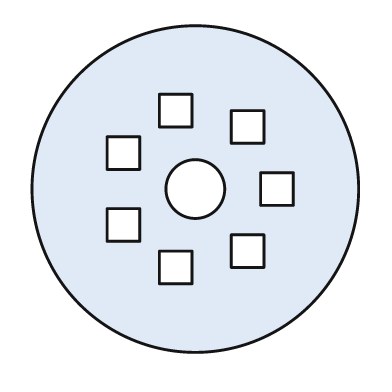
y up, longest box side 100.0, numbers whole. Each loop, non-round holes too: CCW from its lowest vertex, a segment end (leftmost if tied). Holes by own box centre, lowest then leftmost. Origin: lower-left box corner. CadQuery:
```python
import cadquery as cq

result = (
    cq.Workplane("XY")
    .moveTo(50.0, 50.0)
    .circle(50.0)
    .moveTo(39.0, 21.0)
    .lineTo(49.0, 21.0)
    .lineTo(49.0, 31.0)
    .lineTo(39.0, 31.0)
    .close()
    .moveTo(61.0, 26.0)
    .lineTo(71.0, 26.0)
    .lineTo(71.0, 36.0)
    .lineTo(61.0, 36.0)
    .close()
    .moveTo(23.0, 34.0)
    .lineTo(33.0, 34.0)
    .lineTo(33.0, 44.0)
    .lineTo(23.0, 44.0)
    .close()
    .moveTo(50.0, 50.0)
    .circle(9.0)
    .moveTo(70.0, 45.0)
    .lineTo(80.0, 45.0)
    .lineTo(80.0, 55.0)
    .lineTo(70.0, 55.0)
    .close()
    .moveTo(23.0, 56.0)
    .lineTo(33.0, 56.0)
    .lineTo(33.0, 66.0)
    .lineTo(23.0, 66.0)
    .close()
    .moveTo(61.0, 64.0)
    .lineTo(71.0, 64.0)
    .lineTo(71.0, 74.0)
    .lineTo(61.0, 74.0)
    .close()
    .moveTo(39.0, 69.0)
    .lineTo(49.0, 69.0)
    .lineTo(49.0, 79.0)
    .lineTo(39.0, 79.0)
    .close()
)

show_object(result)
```